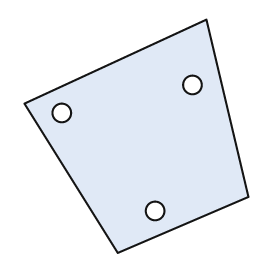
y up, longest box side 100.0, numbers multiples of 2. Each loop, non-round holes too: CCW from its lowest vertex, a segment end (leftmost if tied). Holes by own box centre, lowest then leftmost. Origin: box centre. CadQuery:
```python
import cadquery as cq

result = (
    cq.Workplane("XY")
    .moveTo(-8.0, -50.0)
    .lineTo(48.0, -26.0)
    .lineTo(30.0, 50.0)
    .lineTo(-48.0, 14.0)
    .close()
    .moveTo(8.0, -32.0)
    .circle(4.0)
    .moveTo(-32.0, 10.0)
    .circle(4.0)
    .moveTo(24.0, 22.0)
    .circle(4.0)
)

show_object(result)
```